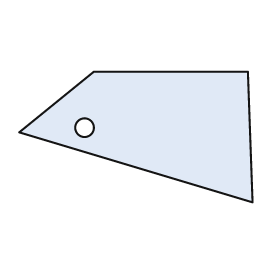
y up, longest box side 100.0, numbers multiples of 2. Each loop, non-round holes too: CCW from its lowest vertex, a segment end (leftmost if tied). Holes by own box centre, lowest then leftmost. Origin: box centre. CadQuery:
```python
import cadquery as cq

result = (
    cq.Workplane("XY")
    .moveTo(50.0, -28.0)
    .lineTo(48.0, 28.0)
    .lineTo(-18.0, 28.0)
    .lineTo(-50.0, 2.0)
    .close()
    .moveTo(-22.0, 4.0)
    .circle(4.0)
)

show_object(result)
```